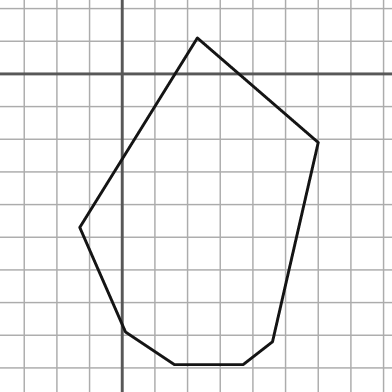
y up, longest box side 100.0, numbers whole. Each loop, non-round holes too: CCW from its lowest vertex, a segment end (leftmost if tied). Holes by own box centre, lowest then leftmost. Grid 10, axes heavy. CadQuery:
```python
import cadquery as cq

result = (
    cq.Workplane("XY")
    .moveTo(16.0, -89.0)
    .lineTo(37.0, -89.0)
    .lineTo(46.0, -82.0)
    .lineTo(60.0, -21.0)
    .lineTo(23.0, 11.0)
    .lineTo(-13.0, -47.0)
    .lineTo(1.0, -79.0)
    .close()
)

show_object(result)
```